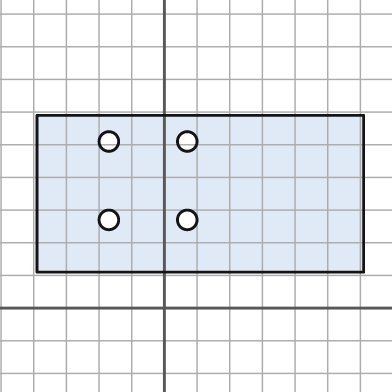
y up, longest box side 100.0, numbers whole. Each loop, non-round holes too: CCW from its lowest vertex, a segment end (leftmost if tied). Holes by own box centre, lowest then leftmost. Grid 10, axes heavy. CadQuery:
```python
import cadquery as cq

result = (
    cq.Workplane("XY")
    .moveTo(-39.0, 11.0)
    .lineTo(61.0, 11.0)
    .lineTo(61.0, 59.0)
    .lineTo(-39.0, 59.0)
    .close()
    .moveTo(-17.0, 27.0)
    .circle(3.0)
    .moveTo(7.0, 27.0)
    .circle(3.0)
    .moveTo(-17.0, 51.0)
    .circle(3.0)
    .moveTo(7.0, 51.0)
    .circle(3.0)
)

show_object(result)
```